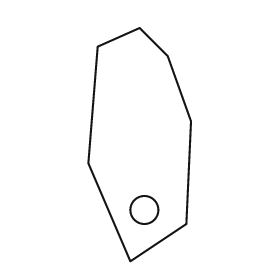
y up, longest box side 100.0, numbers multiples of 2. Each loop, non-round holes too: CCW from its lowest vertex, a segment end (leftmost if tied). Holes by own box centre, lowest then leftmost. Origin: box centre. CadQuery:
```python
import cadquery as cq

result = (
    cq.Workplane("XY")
    .moveTo(-4.0, -50.0)
    .lineTo(20.0, -34.0)
    .lineTo(22.0, 10.0)
    .lineTo(12.0, 38.0)
    .lineTo(0.0, 50.0)
    .lineTo(-18.0, 42.0)
    .lineTo(-22.0, -8.0)
    .close()
    .moveTo(2.0, -28.0)
    .circle(6.0)
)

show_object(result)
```